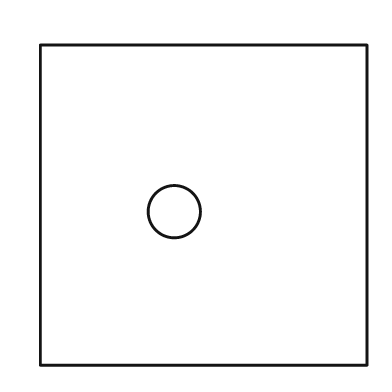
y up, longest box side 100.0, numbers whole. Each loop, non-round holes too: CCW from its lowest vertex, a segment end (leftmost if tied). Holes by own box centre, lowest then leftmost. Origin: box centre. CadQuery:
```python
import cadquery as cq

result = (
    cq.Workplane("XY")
    .moveTo(-50.0, -49.0)
    .lineTo(50.0, -49.0)
    .lineTo(50.0, 49.0)
    .lineTo(-50.0, 49.0)
    .close()
    .moveTo(-9.0, -2.0)
    .circle(8.0)
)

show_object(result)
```